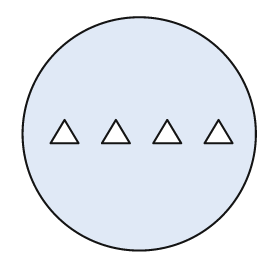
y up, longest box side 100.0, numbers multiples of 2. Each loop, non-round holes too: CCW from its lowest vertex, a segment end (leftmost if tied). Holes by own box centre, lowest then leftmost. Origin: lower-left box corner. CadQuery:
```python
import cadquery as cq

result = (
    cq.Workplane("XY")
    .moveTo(50.0, 50.0)
    .circle(50.0)
    .moveTo(12.0, 46.0)
    .lineTo(24.0, 46.0)
    .lineTo(18.0, 56.0)
    .close()
    .moveTo(34.0, 46.0)
    .lineTo(46.0, 46.0)
    .lineTo(40.0, 56.0)
    .close()
    .moveTo(56.0, 46.0)
    .lineTo(68.0, 46.0)
    .lineTo(62.0, 56.0)
    .close()
    .moveTo(78.0, 46.0)
    .lineTo(90.0, 46.0)
    .lineTo(84.0, 56.0)
    .close()
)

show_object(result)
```